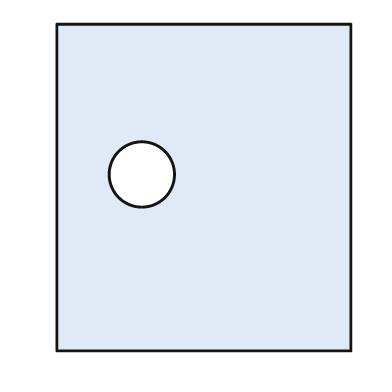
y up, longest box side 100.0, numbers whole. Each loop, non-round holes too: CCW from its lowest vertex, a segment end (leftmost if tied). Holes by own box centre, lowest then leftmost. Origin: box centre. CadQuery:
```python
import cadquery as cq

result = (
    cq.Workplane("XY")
    .moveTo(-45.0, -50.0)
    .lineTo(45.0, -50.0)
    .lineTo(45.0, 50.0)
    .lineTo(-45.0, 50.0)
    .close()
    .moveTo(-19.0, 4.0)
    .circle(10.0)
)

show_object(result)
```